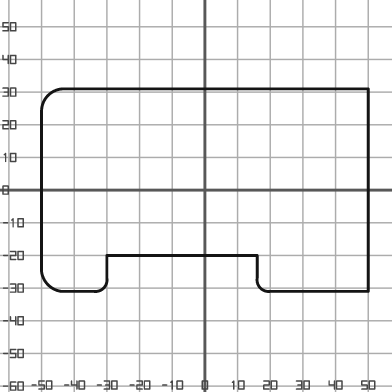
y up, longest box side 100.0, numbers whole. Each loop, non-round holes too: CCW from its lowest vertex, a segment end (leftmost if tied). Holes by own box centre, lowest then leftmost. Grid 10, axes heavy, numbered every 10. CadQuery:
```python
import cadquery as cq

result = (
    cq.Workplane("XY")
    .moveTo(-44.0, -31.0)
    .lineTo(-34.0, -31.0)
    .threePointArc((-31.0, -30.0), (-30.0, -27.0))
    .lineTo(-30.0, -20.0)
    .lineTo(16.0, -20.0)
    .lineTo(16.0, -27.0)
    .threePointArc((17.0, -30.0), (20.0, -31.0))
    .lineTo(50.0, -31.0)
    .lineTo(50.0, 31.0)
    .lineTo(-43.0, 31.0)
    .threePointArc((-48.0, 29.0), (-50.0, 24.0))
    .lineTo(-50.0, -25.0)
    .threePointArc((-48.0, -29.0), (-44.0, -31.0))
    .close()
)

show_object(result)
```